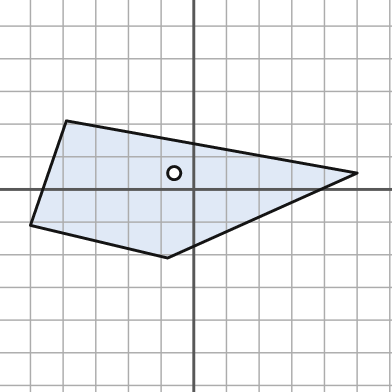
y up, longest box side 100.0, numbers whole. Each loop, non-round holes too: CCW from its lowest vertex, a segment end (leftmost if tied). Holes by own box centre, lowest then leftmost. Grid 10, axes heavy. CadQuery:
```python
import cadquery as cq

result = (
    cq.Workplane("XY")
    .moveTo(-8.0, -21.0)
    .lineTo(50.0, 5.0)
    .lineTo(-39.0, 21.0)
    .lineTo(-50.0, -11.0)
    .close()
    .moveTo(-6.0, 5.0)
    .circle(2.0)
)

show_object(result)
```